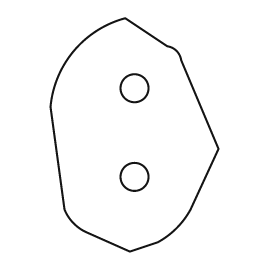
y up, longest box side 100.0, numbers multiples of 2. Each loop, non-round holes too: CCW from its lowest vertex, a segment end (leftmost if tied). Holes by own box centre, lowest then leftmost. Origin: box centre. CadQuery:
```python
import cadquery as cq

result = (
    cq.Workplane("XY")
    .moveTo(-2.0, -50.0)
    .lineTo(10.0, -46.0)
    .threePointArc((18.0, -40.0), (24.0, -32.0))
    .lineTo(36.0, -6.0)
    .lineTo(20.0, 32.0)
    .threePointArc((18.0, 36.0), (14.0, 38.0))
    .lineTo(-4.0, 50.0)
    .threePointArc((-26.0, 36.0), (-36.0, 12.0))
    .lineTo(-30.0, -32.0)
    .threePointArc((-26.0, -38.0), (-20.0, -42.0))
    .close()
    .moveTo(0.0, -18.0)
    .circle(6.0)
    .moveTo(0.0, 20.0)
    .circle(6.0)
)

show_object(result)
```